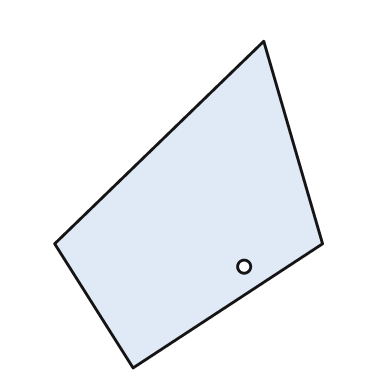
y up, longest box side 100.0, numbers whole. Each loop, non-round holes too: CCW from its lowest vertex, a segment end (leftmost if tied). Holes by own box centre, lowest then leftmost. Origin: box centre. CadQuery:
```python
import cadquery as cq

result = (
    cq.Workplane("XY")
    .moveTo(-17.0, -50.0)
    .lineTo(41.0, -12.0)
    .lineTo(23.0, 50.0)
    .lineTo(-41.0, -12.0)
    .close()
    .moveTo(17.0, -19.0)
    .circle(2.0)
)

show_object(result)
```